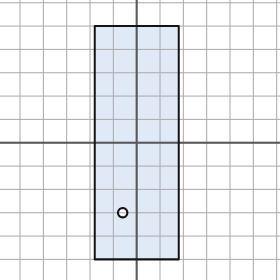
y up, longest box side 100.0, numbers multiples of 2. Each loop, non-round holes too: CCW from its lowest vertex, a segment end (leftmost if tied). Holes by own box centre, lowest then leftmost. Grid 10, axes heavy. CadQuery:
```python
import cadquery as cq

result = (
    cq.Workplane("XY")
    .moveTo(-18.0, -50.0)
    .lineTo(18.0, -50.0)
    .lineTo(18.0, 50.0)
    .lineTo(-18.0, 50.0)
    .close()
    .moveTo(-6.0, -30.0)
    .circle(2.0)
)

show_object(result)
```